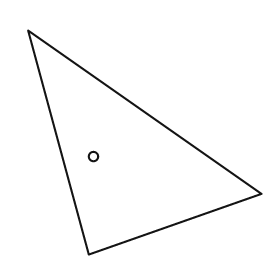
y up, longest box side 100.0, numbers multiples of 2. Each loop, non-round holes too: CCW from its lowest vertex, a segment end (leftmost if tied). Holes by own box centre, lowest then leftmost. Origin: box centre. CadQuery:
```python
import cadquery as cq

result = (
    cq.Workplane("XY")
    .moveTo(-24.0, -48.0)
    .lineTo(50.0, -22.0)
    .lineTo(-50.0, 48.0)
    .close()
    .moveTo(-22.0, -6.0)
    .circle(2.0)
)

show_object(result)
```